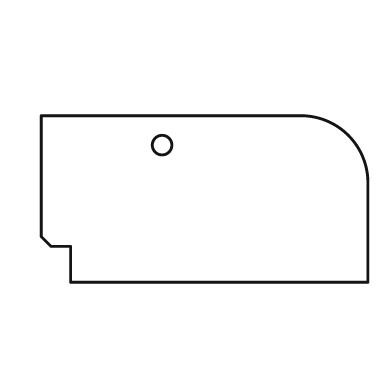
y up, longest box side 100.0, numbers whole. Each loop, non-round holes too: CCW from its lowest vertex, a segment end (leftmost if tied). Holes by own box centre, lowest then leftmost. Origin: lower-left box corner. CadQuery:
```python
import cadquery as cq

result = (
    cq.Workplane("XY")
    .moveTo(9.0, 0.0)
    .lineTo(100.0, 0.0)
    .lineTo(100.0, 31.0)
    .threePointArc((94.0, 45.0), (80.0, 51.0))
    .lineTo(0.0, 51.0)
    .lineTo(0.0, 14.0)
    .lineTo(3.0, 11.0)
    .lineTo(9.0, 11.0)
    .close()
    .moveTo(37.0, 42.0)
    .circle(3.0)
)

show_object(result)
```